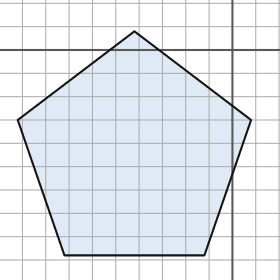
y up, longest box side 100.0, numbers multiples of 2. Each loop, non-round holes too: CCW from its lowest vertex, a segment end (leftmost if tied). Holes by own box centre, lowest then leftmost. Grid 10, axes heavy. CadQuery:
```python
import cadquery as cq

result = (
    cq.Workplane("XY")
    .moveTo(-72.0, -88.0)
    .lineTo(-12.0, -88.0)
    .lineTo(8.0, -30.0)
    .lineTo(-42.0, 8.0)
    .lineTo(-92.0, -30.0)
    .close()
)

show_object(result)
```